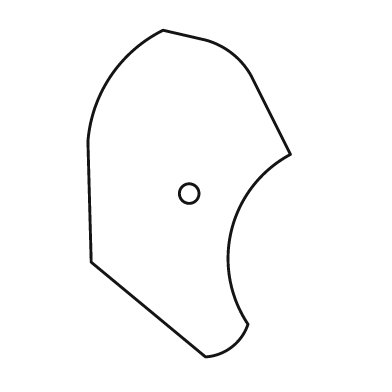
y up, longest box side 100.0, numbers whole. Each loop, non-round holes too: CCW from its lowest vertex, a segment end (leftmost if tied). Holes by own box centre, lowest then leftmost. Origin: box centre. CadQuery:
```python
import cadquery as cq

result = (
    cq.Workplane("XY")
    .moveTo(5.0, -50.0)
    .threePointArc((13.0, -47.0), (18.0, -40.0))
    .threePointArc((13.0, -11.0), (31.0, 12.0))
    .lineTo(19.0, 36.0)
    .threePointArc((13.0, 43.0), (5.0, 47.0))
    .lineTo(-8.0, 50.0)
    .threePointArc((-24.0, 36.0), (-31.0, 16.0))
    .lineTo(-30.0, -21.0)
    .close()
    .moveTo(0.0, 0.0)
    .circle(3.0)
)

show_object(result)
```